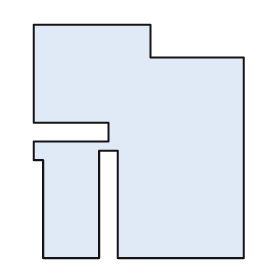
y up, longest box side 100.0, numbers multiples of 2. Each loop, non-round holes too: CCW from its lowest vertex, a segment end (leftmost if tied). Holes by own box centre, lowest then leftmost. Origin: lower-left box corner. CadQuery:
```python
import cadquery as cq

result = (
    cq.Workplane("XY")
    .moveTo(4.0, 0.0)
    .lineTo(28.0, 0.0)
    .lineTo(28.0, 46.0)
    .lineTo(36.0, 46.0)
    .lineTo(36.0, 0.0)
    .lineTo(90.0, 0.0)
    .lineTo(90.0, 86.0)
    .lineTo(50.0, 86.0)
    .lineTo(50.0, 100.0)
    .lineTo(0.0, 100.0)
    .lineTo(0.0, 58.0)
    .lineTo(32.0, 58.0)
    .lineTo(32.0, 50.0)
    .lineTo(0.0, 50.0)
    .lineTo(0.0, 42.0)
    .lineTo(4.0, 42.0)
    .close()
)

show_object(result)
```